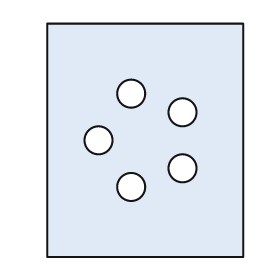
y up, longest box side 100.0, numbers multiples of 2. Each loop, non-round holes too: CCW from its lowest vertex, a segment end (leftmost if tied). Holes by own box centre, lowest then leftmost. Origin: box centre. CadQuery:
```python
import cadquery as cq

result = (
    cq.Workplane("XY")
    .moveTo(-42.0, -50.0)
    .lineTo(42.0, -50.0)
    .lineTo(42.0, 50.0)
    .lineTo(-42.0, 50.0)
    .close()
    .moveTo(-6.0, -20.0)
    .circle(6.0)
    .moveTo(16.0, -12.0)
    .circle(6.0)
    .moveTo(-20.0, 0.0)
    .circle(6.0)
    .moveTo(16.0, 12.0)
    .circle(6.0)
    .moveTo(-6.0, 20.0)
    .circle(6.0)
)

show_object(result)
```